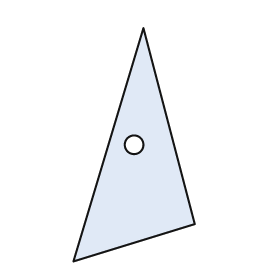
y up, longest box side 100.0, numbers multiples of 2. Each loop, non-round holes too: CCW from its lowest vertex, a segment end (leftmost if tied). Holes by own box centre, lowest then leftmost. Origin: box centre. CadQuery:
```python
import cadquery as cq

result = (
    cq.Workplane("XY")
    .moveTo(-26.0, -50.0)
    .lineTo(26.0, -34.0)
    .lineTo(4.0, 50.0)
    .close()
    .moveTo(0.0, 0.0)
    .circle(4.0)
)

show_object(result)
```